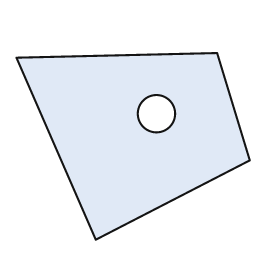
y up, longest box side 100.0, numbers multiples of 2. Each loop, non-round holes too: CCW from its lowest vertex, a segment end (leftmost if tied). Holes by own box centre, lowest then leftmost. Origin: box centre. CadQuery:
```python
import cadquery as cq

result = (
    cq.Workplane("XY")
    .moveTo(-16.0, -40.0)
    .lineTo(50.0, -6.0)
    .lineTo(36.0, 40.0)
    .lineTo(-50.0, 38.0)
    .close()
    .moveTo(10.0, 14.0)
    .circle(8.0)
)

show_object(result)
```